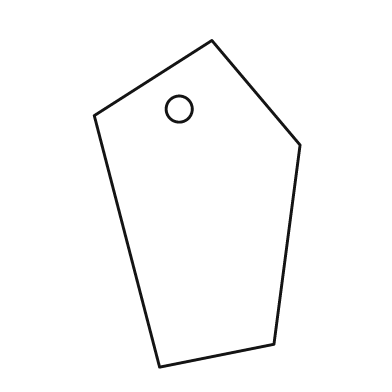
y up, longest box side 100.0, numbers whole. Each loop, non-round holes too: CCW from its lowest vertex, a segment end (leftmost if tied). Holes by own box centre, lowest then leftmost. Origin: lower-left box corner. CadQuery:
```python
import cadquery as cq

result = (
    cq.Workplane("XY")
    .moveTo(20.0, 0.0)
    .lineTo(55.0, 7.0)
    .lineTo(63.0, 68.0)
    .lineTo(36.0, 100.0)
    .lineTo(0.0, 77.0)
    .close()
    .moveTo(26.0, 79.0)
    .circle(4.0)
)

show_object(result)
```